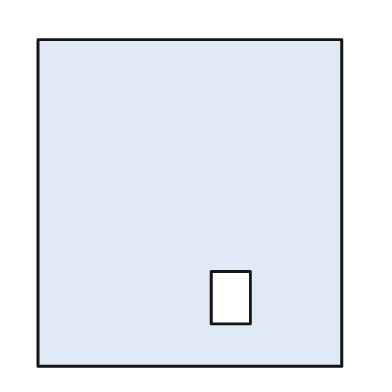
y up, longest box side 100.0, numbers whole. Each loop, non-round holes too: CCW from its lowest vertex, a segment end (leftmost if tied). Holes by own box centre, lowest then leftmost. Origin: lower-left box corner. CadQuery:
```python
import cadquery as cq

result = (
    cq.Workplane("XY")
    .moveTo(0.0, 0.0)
    .lineTo(93.0, 0.0)
    .lineTo(93.0, 100.0)
    .lineTo(0.0, 100.0)
    .close()
    .moveTo(53.0, 13.0)
    .lineTo(65.0, 13.0)
    .lineTo(65.0, 29.0)
    .lineTo(53.0, 29.0)
    .close()
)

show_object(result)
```